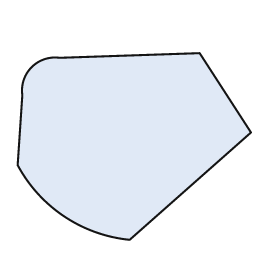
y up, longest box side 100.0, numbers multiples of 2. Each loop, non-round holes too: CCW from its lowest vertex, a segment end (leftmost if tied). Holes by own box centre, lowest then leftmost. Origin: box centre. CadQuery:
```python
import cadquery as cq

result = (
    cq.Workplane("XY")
    .moveTo(-2.0, -40.0)
    .lineTo(50.0, 6.0)
    .lineTo(28.0, 40.0)
    .lineTo(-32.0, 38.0)
    .threePointArc((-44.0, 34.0), (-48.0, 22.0))
    .lineTo(-50.0, -8.0)
    .threePointArc((-30.0, -30.0), (-2.0, -40.0))
    .close()
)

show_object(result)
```